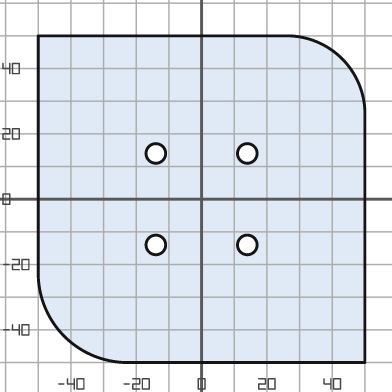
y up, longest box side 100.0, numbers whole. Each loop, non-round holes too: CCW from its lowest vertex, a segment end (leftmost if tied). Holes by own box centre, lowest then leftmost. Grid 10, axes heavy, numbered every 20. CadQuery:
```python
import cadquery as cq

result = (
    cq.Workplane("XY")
    .moveTo(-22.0, -50.0)
    .lineTo(50.0, -50.0)
    .lineTo(50.0, 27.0)
    .threePointArc((43.0, 43.0), (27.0, 50.0))
    .lineTo(-50.0, 50.0)
    .lineTo(-50.0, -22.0)
    .threePointArc((-42.0, -42.0), (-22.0, -50.0))
    .close()
    .moveTo(-14.0, -14.0)
    .circle(3.0)
    .moveTo(14.0, -14.0)
    .circle(3.0)
    .moveTo(-14.0, 14.0)
    .circle(3.0)
    .moveTo(14.0, 14.0)
    .circle(3.0)
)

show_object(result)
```